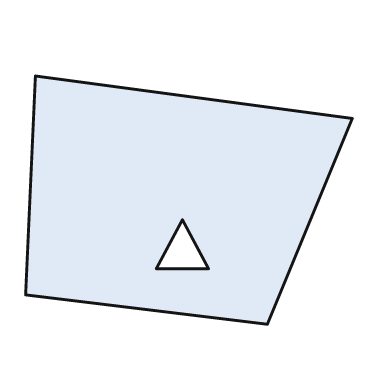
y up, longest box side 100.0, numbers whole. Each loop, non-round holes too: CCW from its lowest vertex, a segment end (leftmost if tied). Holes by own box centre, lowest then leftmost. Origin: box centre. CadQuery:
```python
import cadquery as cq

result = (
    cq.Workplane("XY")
    .moveTo(24.0, -38.0)
    .lineTo(50.0, 25.0)
    .lineTo(-47.0, 38.0)
    .lineTo(-50.0, -29.0)
    .close()
    .moveTo(-10.0, -21.0)
    .lineTo(6.0, -21.0)
    .lineTo(-2.0, -6.0)
    .close()
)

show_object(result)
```